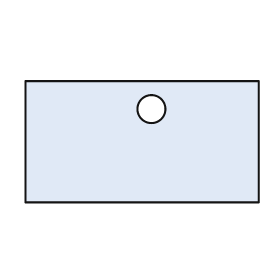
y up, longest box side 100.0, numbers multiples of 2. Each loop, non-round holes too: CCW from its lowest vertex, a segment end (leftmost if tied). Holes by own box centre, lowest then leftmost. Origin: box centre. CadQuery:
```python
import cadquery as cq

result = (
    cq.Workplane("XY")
    .moveTo(-50.0, -26.0)
    .lineTo(50.0, -26.0)
    .lineTo(50.0, 26.0)
    .lineTo(-50.0, 26.0)
    .close()
    .moveTo(4.0, 14.0)
    .circle(6.0)
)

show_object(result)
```